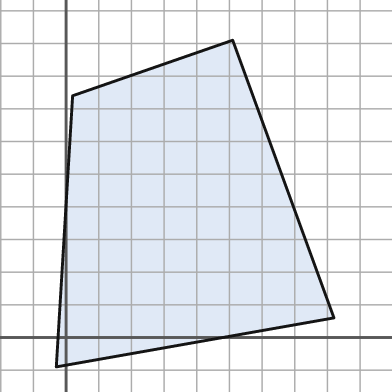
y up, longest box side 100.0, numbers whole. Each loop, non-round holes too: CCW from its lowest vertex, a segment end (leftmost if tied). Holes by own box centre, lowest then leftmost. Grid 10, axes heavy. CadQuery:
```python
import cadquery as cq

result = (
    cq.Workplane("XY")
    .moveTo(-3.0, -9.0)
    .lineTo(82.0, 6.0)
    .lineTo(51.0, 91.0)
    .lineTo(2.0, 74.0)
    .close()
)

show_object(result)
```